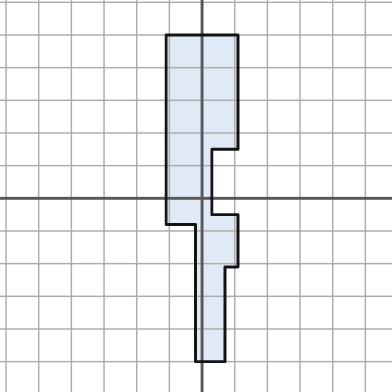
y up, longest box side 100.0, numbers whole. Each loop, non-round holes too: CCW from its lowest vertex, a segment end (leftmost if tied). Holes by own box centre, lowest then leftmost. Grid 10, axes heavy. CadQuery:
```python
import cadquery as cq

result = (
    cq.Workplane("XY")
    .moveTo(-2.0, -50.0)
    .lineTo(7.0, -50.0)
    .lineTo(7.0, -21.0)
    .lineTo(11.0, -21.0)
    .lineTo(11.0, -5.0)
    .lineTo(3.0, -5.0)
    .lineTo(3.0, 15.0)
    .lineTo(11.0, 15.0)
    .lineTo(11.0, 50.0)
    .lineTo(-11.0, 50.0)
    .lineTo(-11.0, -8.0)
    .lineTo(-2.0, -8.0)
    .close()
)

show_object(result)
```